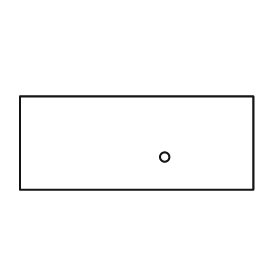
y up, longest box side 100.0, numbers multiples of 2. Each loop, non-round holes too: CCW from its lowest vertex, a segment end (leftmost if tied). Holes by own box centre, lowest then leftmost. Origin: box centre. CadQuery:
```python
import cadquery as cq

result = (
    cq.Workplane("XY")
    .moveTo(-50.0, -20.0)
    .lineTo(50.0, -20.0)
    .lineTo(50.0, 20.0)
    .lineTo(-50.0, 20.0)
    .close()
    .moveTo(12.0, -6.0)
    .circle(2.0)
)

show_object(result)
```